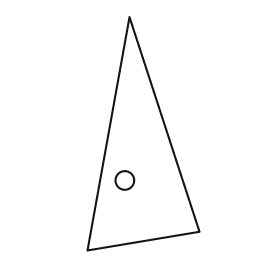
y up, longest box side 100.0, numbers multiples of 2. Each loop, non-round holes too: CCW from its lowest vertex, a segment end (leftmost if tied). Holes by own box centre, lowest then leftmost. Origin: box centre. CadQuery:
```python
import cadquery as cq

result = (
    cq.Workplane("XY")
    .moveTo(-24.0, -50.0)
    .lineTo(24.0, -42.0)
    .lineTo(-6.0, 50.0)
    .close()
    .moveTo(-8.0, -20.0)
    .circle(4.0)
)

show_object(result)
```